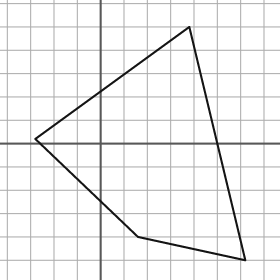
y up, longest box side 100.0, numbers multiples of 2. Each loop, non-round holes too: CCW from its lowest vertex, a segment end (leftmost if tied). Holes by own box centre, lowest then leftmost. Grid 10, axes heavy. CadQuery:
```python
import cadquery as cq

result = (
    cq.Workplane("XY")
    .moveTo(62.0, -50.0)
    .lineTo(38.0, 50.0)
    .lineTo(-28.0, 2.0)
    .lineTo(16.0, -40.0)
    .close()
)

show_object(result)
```